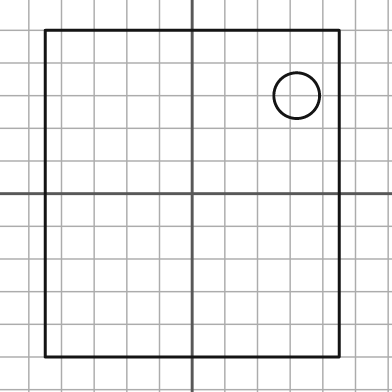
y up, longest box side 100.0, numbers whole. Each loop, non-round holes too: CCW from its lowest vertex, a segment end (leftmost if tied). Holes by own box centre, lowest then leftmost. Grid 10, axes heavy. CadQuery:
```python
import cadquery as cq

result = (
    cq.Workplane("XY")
    .moveTo(-45.0, -50.0)
    .lineTo(45.0, -50.0)
    .lineTo(45.0, 50.0)
    .lineTo(-45.0, 50.0)
    .close()
    .moveTo(32.0, 30.0)
    .circle(7.0)
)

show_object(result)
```